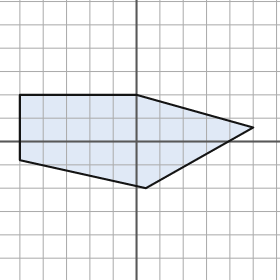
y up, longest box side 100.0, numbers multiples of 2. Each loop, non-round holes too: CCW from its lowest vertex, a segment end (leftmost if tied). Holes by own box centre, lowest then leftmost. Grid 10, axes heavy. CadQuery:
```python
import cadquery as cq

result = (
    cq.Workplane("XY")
    .moveTo(4.0, -20.0)
    .lineTo(50.0, 6.0)
    .lineTo(0.0, 20.0)
    .lineTo(-50.0, 20.0)
    .lineTo(-50.0, -8.0)
    .close()
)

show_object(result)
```